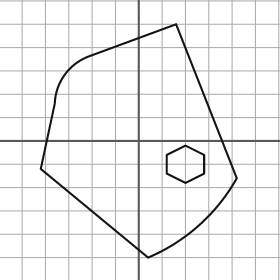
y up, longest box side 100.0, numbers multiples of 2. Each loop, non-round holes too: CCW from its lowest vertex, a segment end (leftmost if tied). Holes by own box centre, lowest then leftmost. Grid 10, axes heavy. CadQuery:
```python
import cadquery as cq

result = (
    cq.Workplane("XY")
    .moveTo(4.0, -50.0)
    .threePointArc((26.0, -36.0), (42.0, -16.0))
    .lineTo(16.0, 50.0)
    .lineTo(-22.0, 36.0)
    .threePointArc((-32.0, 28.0), (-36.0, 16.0))
    .lineTo(-42.0, -12.0)
    .close()
    .moveTo(20.0, -18.0)
    .lineTo(28.0, -14.0)
    .lineTo(28.0, -6.0)
    .lineTo(20.0, -2.0)
    .lineTo(12.0, -6.0)
    .lineTo(12.0, -14.0)
    .close()
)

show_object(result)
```